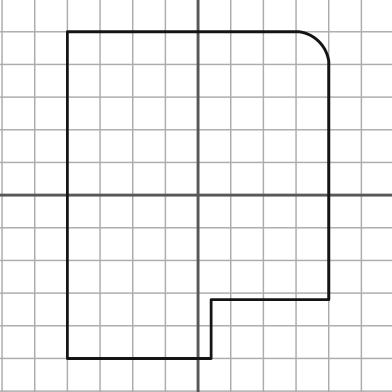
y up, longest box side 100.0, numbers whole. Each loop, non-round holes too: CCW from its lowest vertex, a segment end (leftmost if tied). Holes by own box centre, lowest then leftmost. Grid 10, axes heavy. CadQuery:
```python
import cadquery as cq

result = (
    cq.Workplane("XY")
    .moveTo(-40.0, -50.0)
    .lineTo(4.0, -50.0)
    .lineTo(4.0, -32.0)
    .lineTo(40.0, -32.0)
    .lineTo(40.0, 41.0)
    .threePointArc((37.0, 47.0), (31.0, 50.0))
    .lineTo(-40.0, 50.0)
    .close()
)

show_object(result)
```